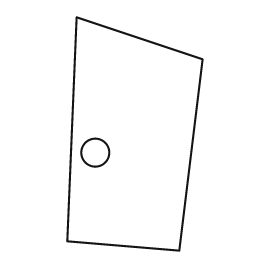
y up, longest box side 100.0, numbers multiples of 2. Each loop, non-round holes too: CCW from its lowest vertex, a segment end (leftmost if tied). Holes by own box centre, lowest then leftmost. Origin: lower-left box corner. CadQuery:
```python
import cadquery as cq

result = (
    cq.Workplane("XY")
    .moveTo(48.0, 0.0)
    .lineTo(58.0, 82.0)
    .lineTo(4.0, 100.0)
    .lineTo(0.0, 4.0)
    .close()
    .moveTo(12.0, 42.0)
    .circle(6.0)
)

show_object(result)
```